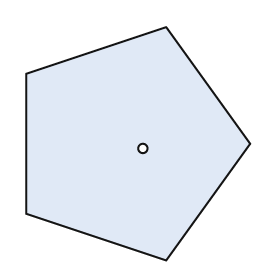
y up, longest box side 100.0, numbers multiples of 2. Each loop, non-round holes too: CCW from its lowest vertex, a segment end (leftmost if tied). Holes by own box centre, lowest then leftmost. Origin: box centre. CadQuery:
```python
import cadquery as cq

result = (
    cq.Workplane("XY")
    .moveTo(12.0, -50.0)
    .lineTo(48.0, 0.0)
    .lineTo(12.0, 50.0)
    .lineTo(-48.0, 30.0)
    .lineTo(-48.0, -30.0)
    .close()
    .moveTo(2.0, -2.0)
    .circle(2.0)
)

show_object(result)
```